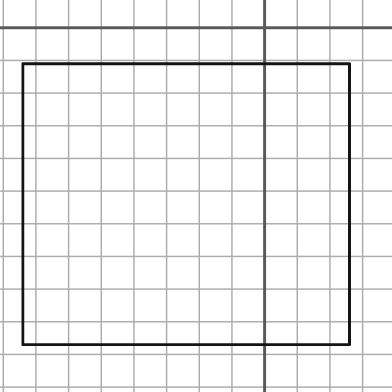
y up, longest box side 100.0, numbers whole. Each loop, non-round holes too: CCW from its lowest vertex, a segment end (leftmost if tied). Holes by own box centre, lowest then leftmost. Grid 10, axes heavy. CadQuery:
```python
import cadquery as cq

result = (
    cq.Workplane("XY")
    .moveTo(-74.0, -97.0)
    .lineTo(26.0, -97.0)
    .lineTo(26.0, -11.0)
    .lineTo(-74.0, -11.0)
    .close()
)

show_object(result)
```